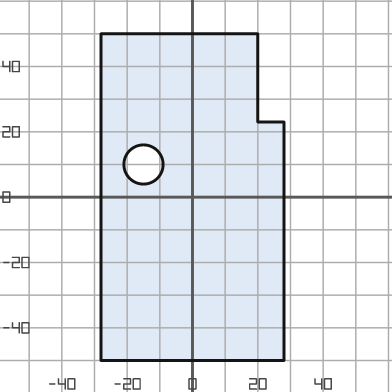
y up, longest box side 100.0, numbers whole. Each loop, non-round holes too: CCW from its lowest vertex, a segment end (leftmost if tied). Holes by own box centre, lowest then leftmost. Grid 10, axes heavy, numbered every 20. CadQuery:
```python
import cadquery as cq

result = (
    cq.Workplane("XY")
    .moveTo(-28.0, -50.0)
    .lineTo(28.0, -50.0)
    .lineTo(28.0, 23.0)
    .lineTo(20.0, 23.0)
    .lineTo(20.0, 50.0)
    .lineTo(-28.0, 50.0)
    .close()
    .moveTo(-15.0, 10.0)
    .circle(6.0)
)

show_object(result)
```